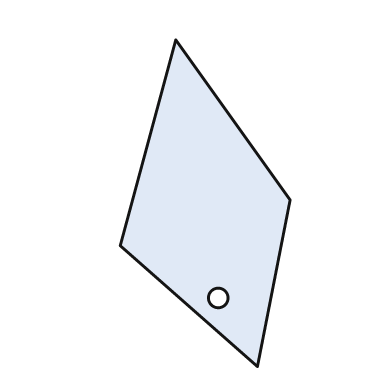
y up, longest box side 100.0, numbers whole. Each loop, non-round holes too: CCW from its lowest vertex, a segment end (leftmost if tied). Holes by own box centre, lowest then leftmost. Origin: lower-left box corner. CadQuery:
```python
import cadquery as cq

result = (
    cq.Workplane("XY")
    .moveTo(42.0, 0.0)
    .lineTo(52.0, 51.0)
    .lineTo(17.0, 100.0)
    .lineTo(0.0, 37.0)
    .close()
    .moveTo(30.0, 21.0)
    .circle(3.0)
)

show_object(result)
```